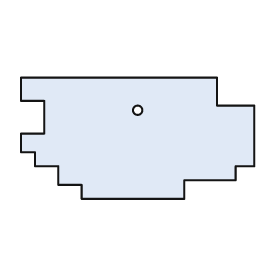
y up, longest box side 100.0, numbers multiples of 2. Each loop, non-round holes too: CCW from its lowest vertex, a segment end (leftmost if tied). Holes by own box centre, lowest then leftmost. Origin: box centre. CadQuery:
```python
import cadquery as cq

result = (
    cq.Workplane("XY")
    .moveTo(-24.0, -26.0)
    .lineTo(20.0, -26.0)
    .lineTo(20.0, -18.0)
    .lineTo(42.0, -18.0)
    .lineTo(42.0, -12.0)
    .lineTo(50.0, -12.0)
    .lineTo(50.0, 14.0)
    .lineTo(34.0, 14.0)
    .lineTo(34.0, 26.0)
    .lineTo(-50.0, 26.0)
    .lineTo(-50.0, 16.0)
    .lineTo(-40.0, 16.0)
    .lineTo(-40.0, 2.0)
    .lineTo(-50.0, 2.0)
    .lineTo(-50.0, -6.0)
    .lineTo(-44.0, -6.0)
    .lineTo(-44.0, -12.0)
    .lineTo(-34.0, -12.0)
    .lineTo(-34.0, -20.0)
    .lineTo(-24.0, -20.0)
    .close()
    .moveTo(0.0, 12.0)
    .circle(2.0)
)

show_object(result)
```